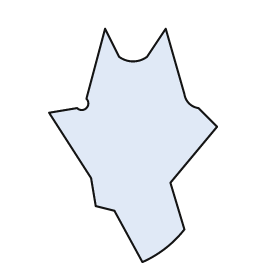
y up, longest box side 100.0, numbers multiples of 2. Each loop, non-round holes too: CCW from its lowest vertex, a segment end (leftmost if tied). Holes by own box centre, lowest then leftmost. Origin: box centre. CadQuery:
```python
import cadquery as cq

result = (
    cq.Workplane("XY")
    .moveTo(4.0, -50.0)
    .threePointArc((14.0, -44.0), (22.0, -36.0))
    .lineTo(16.0, -16.0)
    .lineTo(36.0, 8.0)
    .lineTo(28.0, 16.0)
    .threePointArc((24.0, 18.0), (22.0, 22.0))
    .lineTo(14.0, 50.0)
    .lineTo(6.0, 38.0)
    .threePointArc((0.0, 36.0), (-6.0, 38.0))
    .lineTo(-12.0, 50.0)
    .lineTo(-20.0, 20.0)
    .threePointArc((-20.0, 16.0), (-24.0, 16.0))
    .lineTo(-36.0, 14.0)
    .lineTo(-18.0, -14.0)
    .lineTo(-16.0, -26.0)
    .lineTo(-8.0, -28.0)
    .close()
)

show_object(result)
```